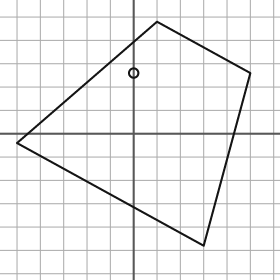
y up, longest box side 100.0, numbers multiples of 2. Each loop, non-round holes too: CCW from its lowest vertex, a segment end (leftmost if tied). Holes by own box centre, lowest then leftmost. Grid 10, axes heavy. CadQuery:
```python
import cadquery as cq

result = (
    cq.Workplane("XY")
    .moveTo(30.0, -48.0)
    .lineTo(50.0, 26.0)
    .lineTo(10.0, 48.0)
    .lineTo(-50.0, -4.0)
    .close()
    .moveTo(0.0, 26.0)
    .circle(2.0)
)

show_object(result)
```